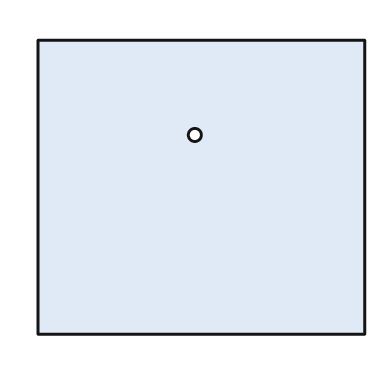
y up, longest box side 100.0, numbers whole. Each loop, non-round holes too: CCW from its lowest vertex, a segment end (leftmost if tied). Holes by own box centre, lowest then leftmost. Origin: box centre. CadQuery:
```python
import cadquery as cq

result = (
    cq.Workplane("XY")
    .moveTo(-50.0, -45.0)
    .lineTo(50.0, -45.0)
    .lineTo(50.0, 45.0)
    .lineTo(-50.0, 45.0)
    .close()
    .moveTo(-2.0, 16.0)
    .circle(2.0)
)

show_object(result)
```